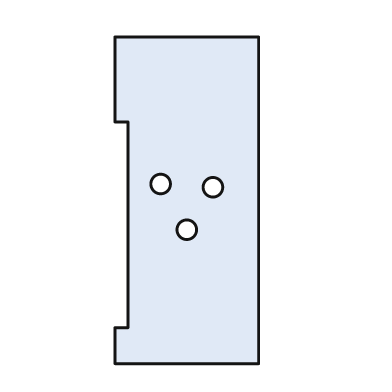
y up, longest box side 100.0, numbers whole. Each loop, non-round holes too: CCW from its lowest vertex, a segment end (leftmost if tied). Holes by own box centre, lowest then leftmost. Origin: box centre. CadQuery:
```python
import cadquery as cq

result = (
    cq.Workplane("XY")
    .moveTo(-22.0, -50.0)
    .lineTo(22.0, -50.0)
    .lineTo(22.0, 50.0)
    .lineTo(-22.0, 50.0)
    .lineTo(-22.0, 24.0)
    .lineTo(-18.0, 24.0)
    .lineTo(-18.0, -39.0)
    .lineTo(-22.0, -39.0)
    .close()
    .moveTo(0.0, -9.0)
    .circle(3.0)
    .moveTo(8.0, 4.0)
    .circle(3.0)
    .moveTo(-8.0, 5.0)
    .circle(3.0)
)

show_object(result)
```